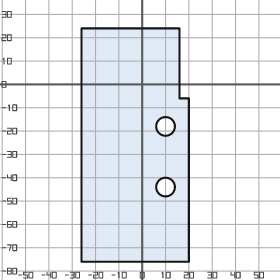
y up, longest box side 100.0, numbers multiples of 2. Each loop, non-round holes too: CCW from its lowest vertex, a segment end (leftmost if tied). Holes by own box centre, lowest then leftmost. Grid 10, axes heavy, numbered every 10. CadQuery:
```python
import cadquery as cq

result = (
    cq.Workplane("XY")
    .moveTo(-26.0, -76.0)
    .lineTo(20.0, -76.0)
    .lineTo(20.0, -6.0)
    .lineTo(16.0, -6.0)
    .lineTo(16.0, 24.0)
    .lineTo(-26.0, 24.0)
    .close()
    .moveTo(10.0, -44.0)
    .circle(4.0)
    .moveTo(10.0, -18.0)
    .circle(4.0)
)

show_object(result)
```